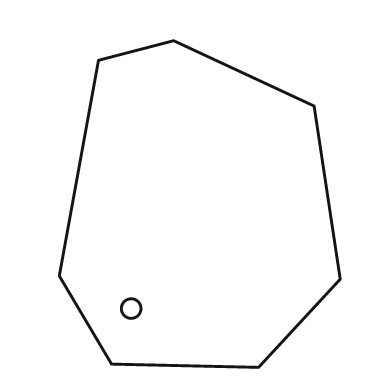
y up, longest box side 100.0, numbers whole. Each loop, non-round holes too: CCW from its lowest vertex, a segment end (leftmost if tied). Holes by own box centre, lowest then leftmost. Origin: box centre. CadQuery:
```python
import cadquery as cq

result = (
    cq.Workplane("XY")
    .moveTo(18.0, -50.0)
    .lineTo(43.0, -23.0)
    .lineTo(35.0, 30.0)
    .lineTo(-8.0, 50.0)
    .lineTo(-31.0, 44.0)
    .lineTo(-43.0, -22.0)
    .lineTo(-27.0, -49.0)
    .close()
    .moveTo(-21.0, -32.0)
    .circle(3.0)
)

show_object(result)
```